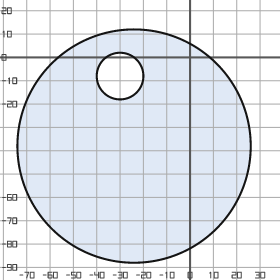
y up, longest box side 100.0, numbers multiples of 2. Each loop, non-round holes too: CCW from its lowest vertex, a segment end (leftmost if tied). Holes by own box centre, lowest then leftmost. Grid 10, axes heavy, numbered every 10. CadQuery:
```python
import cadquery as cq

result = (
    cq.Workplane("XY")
    .moveTo(-24.0, -38.0)
    .circle(50.0)
    .moveTo(-30.0, -8.0)
    .circle(10.0)
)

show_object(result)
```